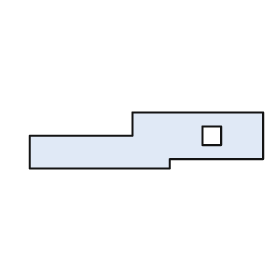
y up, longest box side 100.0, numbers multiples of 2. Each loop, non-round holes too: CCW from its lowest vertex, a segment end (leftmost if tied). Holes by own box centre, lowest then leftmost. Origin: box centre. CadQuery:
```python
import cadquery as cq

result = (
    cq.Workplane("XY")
    .moveTo(-50.0, -12.0)
    .lineTo(10.0, -12.0)
    .lineTo(10.0, -8.0)
    .lineTo(50.0, -8.0)
    .lineTo(50.0, 12.0)
    .lineTo(-6.0, 12.0)
    .lineTo(-6.0, 2.0)
    .lineTo(-50.0, 2.0)
    .close()
    .moveTo(24.0, -2.0)
    .lineTo(32.0, -2.0)
    .lineTo(32.0, 6.0)
    .lineTo(24.0, 6.0)
    .close()
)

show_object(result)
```